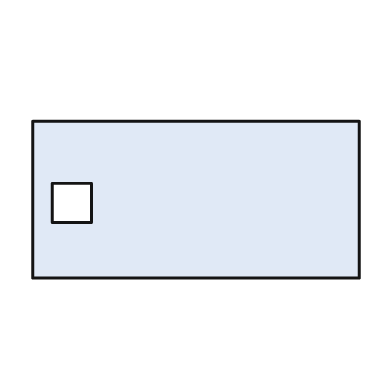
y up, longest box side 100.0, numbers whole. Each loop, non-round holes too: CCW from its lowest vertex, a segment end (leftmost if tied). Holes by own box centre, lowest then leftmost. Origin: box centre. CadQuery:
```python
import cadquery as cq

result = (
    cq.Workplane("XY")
    .moveTo(-50.0, -24.0)
    .lineTo(50.0, -24.0)
    .lineTo(50.0, 24.0)
    .lineTo(-50.0, 24.0)
    .close()
    .moveTo(-44.0, -7.0)
    .lineTo(-32.0, -7.0)
    .lineTo(-32.0, 5.0)
    .lineTo(-44.0, 5.0)
    .close()
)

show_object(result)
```